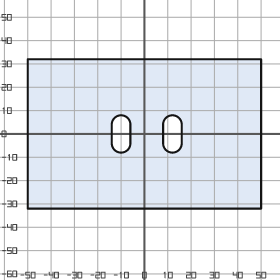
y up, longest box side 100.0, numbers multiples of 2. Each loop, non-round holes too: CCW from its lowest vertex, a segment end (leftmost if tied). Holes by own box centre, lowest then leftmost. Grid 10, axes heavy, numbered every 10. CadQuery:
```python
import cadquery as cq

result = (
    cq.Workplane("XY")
    .moveTo(-50.0, -32.0)
    .lineTo(50.0, -32.0)
    .lineTo(50.0, 32.0)
    .lineTo(-50.0, 32.0)
    .close()
    .moveTo(-14.0, -4.0)
    .threePointArc((-10.0, -8.0), (-6.0, -4.0))
    .lineTo(-6.0, 4.0)
    .threePointArc((-10.0, 8.0), (-14.0, 4.0))
    .close()
    .moveTo(8.0, -4.0)
    .threePointArc((12.0, -8.0), (16.0, -4.0))
    .lineTo(16.0, 4.0)
    .threePointArc((12.0, 8.0), (8.0, 4.0))
    .close()
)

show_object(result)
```